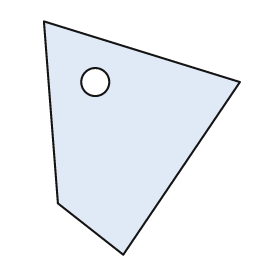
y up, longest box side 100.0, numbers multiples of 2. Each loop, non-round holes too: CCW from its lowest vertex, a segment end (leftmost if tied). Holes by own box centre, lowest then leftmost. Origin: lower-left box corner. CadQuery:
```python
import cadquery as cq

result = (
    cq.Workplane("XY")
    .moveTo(34.0, 0.0)
    .lineTo(84.0, 74.0)
    .lineTo(0.0, 100.0)
    .lineTo(6.0, 22.0)
    .close()
    .moveTo(22.0, 74.0)
    .circle(6.0)
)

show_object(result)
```